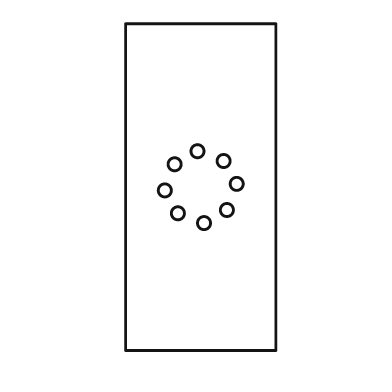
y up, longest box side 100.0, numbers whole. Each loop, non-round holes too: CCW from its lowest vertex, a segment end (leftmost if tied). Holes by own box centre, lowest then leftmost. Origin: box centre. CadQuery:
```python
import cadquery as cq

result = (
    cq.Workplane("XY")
    .moveTo(-23.0, -50.0)
    .lineTo(23.0, -50.0)
    .lineTo(23.0, 50.0)
    .lineTo(-23.0, 50.0)
    .close()
    .moveTo(1.0, -11.0)
    .circle(2.0)
    .moveTo(-7.0, -8.0)
    .circle(2.0)
    .moveTo(8.0, -7.0)
    .circle(2.0)
    .moveTo(-11.0, -1.0)
    .circle(2.0)
    .moveTo(11.0, 1.0)
    .circle(2.0)
    .moveTo(-8.0, 7.0)
    .circle(2.0)
    .moveTo(7.0, 8.0)
    .circle(2.0)
    .moveTo(-1.0, 11.0)
    .circle(2.0)
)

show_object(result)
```